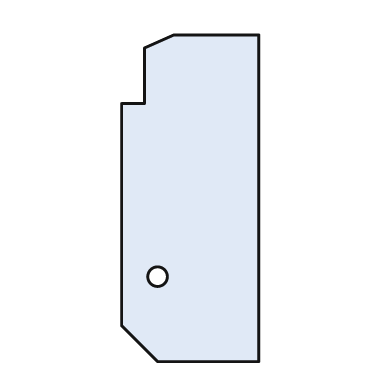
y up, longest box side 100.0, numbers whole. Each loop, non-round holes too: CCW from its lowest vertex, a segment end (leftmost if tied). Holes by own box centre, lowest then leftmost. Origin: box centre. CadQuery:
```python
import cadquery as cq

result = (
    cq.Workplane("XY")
    .moveTo(-10.0, -50.0)
    .lineTo(21.0, -50.0)
    .lineTo(21.0, 50.0)
    .lineTo(-5.0, 50.0)
    .lineTo(-14.0, 46.0)
    .lineTo(-14.0, 29.0)
    .lineTo(-21.0, 29.0)
    .lineTo(-21.0, -39.0)
    .close()
    .moveTo(-10.0, -24.0)
    .circle(3.0)
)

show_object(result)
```